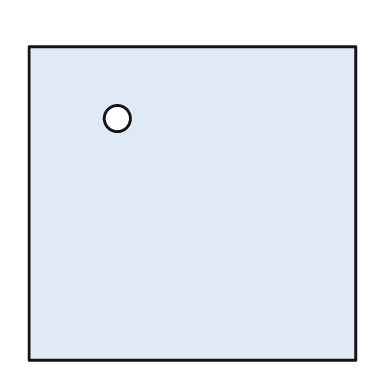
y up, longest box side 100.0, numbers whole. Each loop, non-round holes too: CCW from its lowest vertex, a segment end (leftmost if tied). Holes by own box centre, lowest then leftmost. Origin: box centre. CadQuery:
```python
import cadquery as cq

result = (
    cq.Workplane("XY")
    .moveTo(-50.0, -48.0)
    .lineTo(50.0, -48.0)
    .lineTo(50.0, 48.0)
    .lineTo(-50.0, 48.0)
    .close()
    .moveTo(-23.0, 26.0)
    .circle(4.0)
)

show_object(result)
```